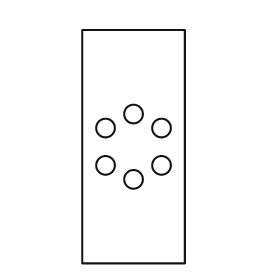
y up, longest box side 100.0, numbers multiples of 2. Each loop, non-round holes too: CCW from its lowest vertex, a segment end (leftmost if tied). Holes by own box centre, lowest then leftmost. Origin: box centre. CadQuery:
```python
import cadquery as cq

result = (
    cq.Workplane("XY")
    .moveTo(-22.0, -50.0)
    .lineTo(22.0, -50.0)
    .lineTo(22.0, 50.0)
    .lineTo(-22.0, 50.0)
    .close()
    .moveTo(0.0, -14.0)
    .circle(4.0)
    .moveTo(-12.0, -8.0)
    .circle(4.0)
    .moveTo(12.0, -8.0)
    .circle(4.0)
    .moveTo(-12.0, 8.0)
    .circle(4.0)
    .moveTo(12.0, 8.0)
    .circle(4.0)
    .moveTo(0.0, 14.0)
    .circle(4.0)
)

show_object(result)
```